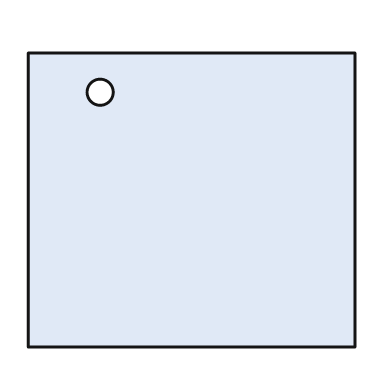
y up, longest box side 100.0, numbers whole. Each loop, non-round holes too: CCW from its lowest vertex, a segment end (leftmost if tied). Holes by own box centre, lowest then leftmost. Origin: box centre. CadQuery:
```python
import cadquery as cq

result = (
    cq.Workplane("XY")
    .moveTo(-50.0, -45.0)
    .lineTo(50.0, -45.0)
    .lineTo(50.0, 45.0)
    .lineTo(-50.0, 45.0)
    .close()
    .moveTo(-28.0, 33.0)
    .circle(4.0)
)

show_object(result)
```